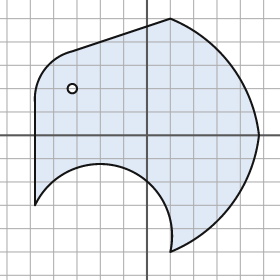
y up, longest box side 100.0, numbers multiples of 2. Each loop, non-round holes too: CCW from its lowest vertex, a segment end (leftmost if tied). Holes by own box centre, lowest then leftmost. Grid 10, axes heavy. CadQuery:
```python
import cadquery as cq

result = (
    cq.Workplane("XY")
    .moveTo(10.0, -50.0)
    .threePointArc((36.0, -30.0), (48.0, 0.0))
    .threePointArc((36.0, 30.0), (10.0, 50.0))
    .lineTo(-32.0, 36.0)
    .threePointArc((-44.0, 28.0), (-48.0, 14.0))
    .lineTo(-48.0, -30.0)
    .threePointArc((-10.0, -14.0), (10.0, -50.0))
    .close()
    .moveTo(-32.0, 20.0)
    .circle(2.0)
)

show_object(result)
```